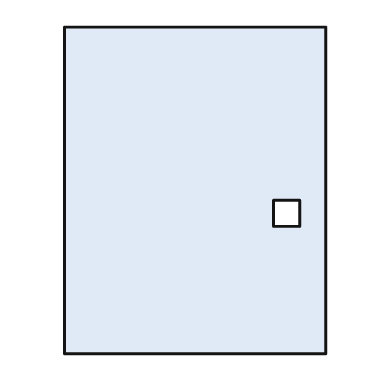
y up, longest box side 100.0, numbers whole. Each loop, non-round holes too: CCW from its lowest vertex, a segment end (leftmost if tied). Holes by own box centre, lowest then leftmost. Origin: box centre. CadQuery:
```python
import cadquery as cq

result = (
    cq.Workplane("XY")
    .moveTo(-40.0, -50.0)
    .lineTo(40.0, -50.0)
    .lineTo(40.0, 50.0)
    .lineTo(-40.0, 50.0)
    .close()
    .moveTo(24.0, -11.0)
    .lineTo(32.0, -11.0)
    .lineTo(32.0, -3.0)
    .lineTo(24.0, -3.0)
    .close()
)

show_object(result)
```